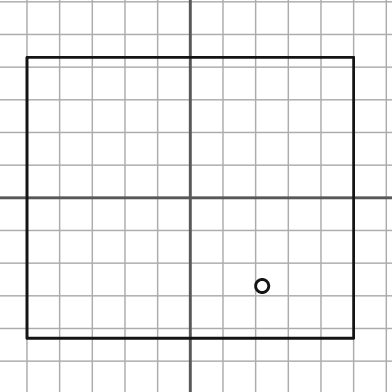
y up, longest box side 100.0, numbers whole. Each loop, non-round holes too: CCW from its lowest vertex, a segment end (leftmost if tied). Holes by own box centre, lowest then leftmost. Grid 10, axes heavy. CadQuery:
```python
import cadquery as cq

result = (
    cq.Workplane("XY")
    .moveTo(-50.0, -43.0)
    .lineTo(50.0, -43.0)
    .lineTo(50.0, 43.0)
    .lineTo(-50.0, 43.0)
    .close()
    .moveTo(22.0, -27.0)
    .circle(2.0)
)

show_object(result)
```